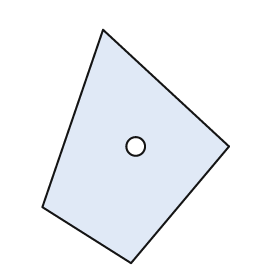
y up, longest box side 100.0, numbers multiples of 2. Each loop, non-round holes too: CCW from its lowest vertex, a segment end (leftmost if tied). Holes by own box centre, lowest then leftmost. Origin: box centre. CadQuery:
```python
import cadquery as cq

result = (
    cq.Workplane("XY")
    .moveTo(-2.0, -50.0)
    .lineTo(40.0, 0.0)
    .lineTo(-14.0, 50.0)
    .lineTo(-40.0, -26.0)
    .close()
    .moveTo(0.0, 0.0)
    .circle(4.0)
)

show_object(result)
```